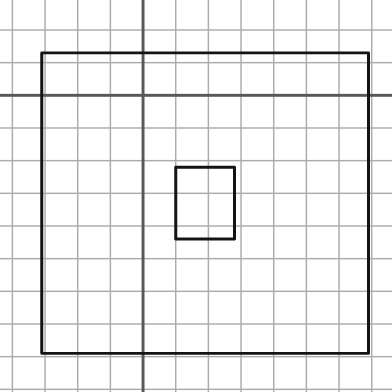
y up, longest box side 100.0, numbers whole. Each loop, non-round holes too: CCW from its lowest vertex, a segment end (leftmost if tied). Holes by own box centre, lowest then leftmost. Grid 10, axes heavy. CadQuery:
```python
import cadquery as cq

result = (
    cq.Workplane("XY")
    .moveTo(-31.0, -79.0)
    .lineTo(69.0, -79.0)
    .lineTo(69.0, 13.0)
    .lineTo(-31.0, 13.0)
    .close()
    .moveTo(10.0, -44.0)
    .lineTo(28.0, -44.0)
    .lineTo(28.0, -22.0)
    .lineTo(10.0, -22.0)
    .close()
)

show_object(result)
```